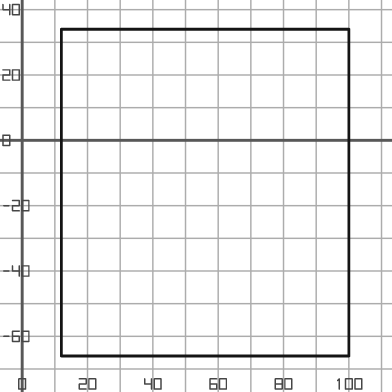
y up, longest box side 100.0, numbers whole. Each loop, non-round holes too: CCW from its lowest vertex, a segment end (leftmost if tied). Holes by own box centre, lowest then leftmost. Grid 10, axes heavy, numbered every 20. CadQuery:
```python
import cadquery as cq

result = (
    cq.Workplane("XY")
    .moveTo(12.0, -66.0)
    .lineTo(100.0, -66.0)
    .lineTo(100.0, 34.0)
    .lineTo(12.0, 34.0)
    .close()
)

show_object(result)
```